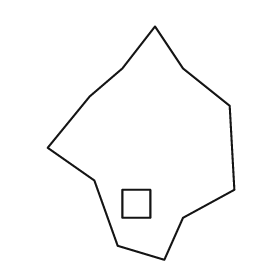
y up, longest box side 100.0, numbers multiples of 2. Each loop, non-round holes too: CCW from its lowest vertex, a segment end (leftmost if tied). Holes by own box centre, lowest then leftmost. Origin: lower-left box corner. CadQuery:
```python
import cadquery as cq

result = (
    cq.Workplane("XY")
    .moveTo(50.0, 0.0)
    .lineTo(58.0, 18.0)
    .lineTo(80.0, 30.0)
    .lineTo(78.0, 66.0)
    .lineTo(58.0, 82.0)
    .lineTo(46.0, 100.0)
    .lineTo(32.0, 82.0)
    .lineTo(18.0, 70.0)
    .lineTo(0.0, 48.0)
    .lineTo(20.0, 34.0)
    .lineTo(30.0, 6.0)
    .close()
    .moveTo(32.0, 18.0)
    .lineTo(44.0, 18.0)
    .lineTo(44.0, 30.0)
    .lineTo(32.0, 30.0)
    .close()
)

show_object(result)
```